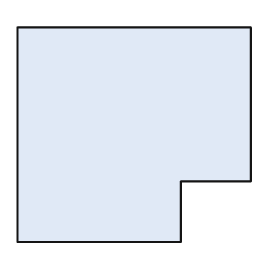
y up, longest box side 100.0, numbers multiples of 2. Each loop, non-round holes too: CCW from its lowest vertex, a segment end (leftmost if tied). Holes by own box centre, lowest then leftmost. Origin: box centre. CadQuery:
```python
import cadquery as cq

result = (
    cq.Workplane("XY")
    .moveTo(-50.0, -46.0)
    .lineTo(20.0, -46.0)
    .lineTo(20.0, -20.0)
    .lineTo(50.0, -20.0)
    .lineTo(50.0, 46.0)
    .lineTo(-50.0, 46.0)
    .close()
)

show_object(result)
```